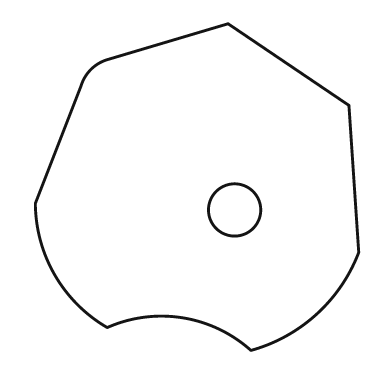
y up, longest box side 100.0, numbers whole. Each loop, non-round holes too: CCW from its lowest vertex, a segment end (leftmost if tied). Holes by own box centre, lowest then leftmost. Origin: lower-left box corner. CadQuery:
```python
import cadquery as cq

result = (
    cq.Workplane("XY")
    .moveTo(66.0, 0.0)
    .threePointArc((86.0, 11.0), (99.0, 30.0))
    .lineTo(96.0, 75.0)
    .lineTo(59.0, 100.0)
    .lineTo(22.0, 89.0)
    .threePointArc((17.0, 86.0), (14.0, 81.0))
    .lineTo(0.0, 45.0)
    .threePointArc((6.0, 23.0), (22.0, 7.0))
    .threePointArc((45.0, 10.0), (66.0, 0.0))
    .close()
    .moveTo(61.0, 43.0)
    .circle(8.0)
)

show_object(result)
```